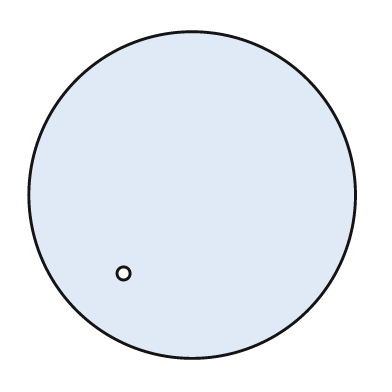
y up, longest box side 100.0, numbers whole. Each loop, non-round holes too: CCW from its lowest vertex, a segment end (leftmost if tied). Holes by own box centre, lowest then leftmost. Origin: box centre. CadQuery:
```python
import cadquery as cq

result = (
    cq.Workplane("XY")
    .moveTo(0.0, 0.0)
    .circle(50.0)
    .moveTo(-21.0, -24.0)
    .circle(2.0)
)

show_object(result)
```